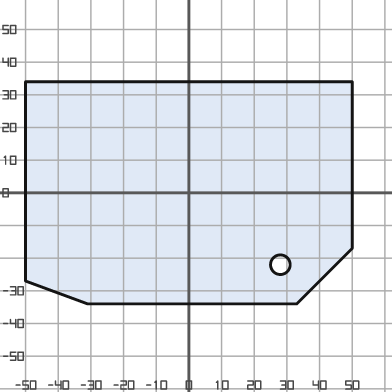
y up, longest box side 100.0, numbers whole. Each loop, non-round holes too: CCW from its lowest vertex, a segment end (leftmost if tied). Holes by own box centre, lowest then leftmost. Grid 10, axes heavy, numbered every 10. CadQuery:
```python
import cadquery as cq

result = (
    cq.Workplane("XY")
    .moveTo(-31.0, -34.0)
    .lineTo(33.0, -34.0)
    .lineTo(50.0, -17.0)
    .lineTo(50.0, 34.0)
    .lineTo(-50.0, 34.0)
    .lineTo(-50.0, -27.0)
    .close()
    .moveTo(28.0, -22.0)
    .circle(3.0)
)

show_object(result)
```